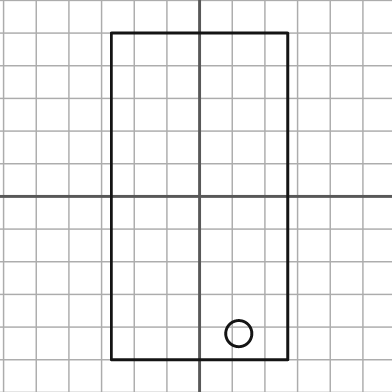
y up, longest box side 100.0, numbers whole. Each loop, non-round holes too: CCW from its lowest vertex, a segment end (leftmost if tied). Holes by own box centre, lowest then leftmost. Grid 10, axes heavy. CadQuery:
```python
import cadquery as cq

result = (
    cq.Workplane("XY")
    .moveTo(-27.0, -50.0)
    .lineTo(27.0, -50.0)
    .lineTo(27.0, 50.0)
    .lineTo(-27.0, 50.0)
    .close()
    .moveTo(12.0, -42.0)
    .circle(4.0)
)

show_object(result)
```